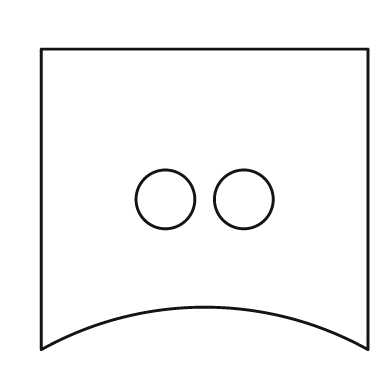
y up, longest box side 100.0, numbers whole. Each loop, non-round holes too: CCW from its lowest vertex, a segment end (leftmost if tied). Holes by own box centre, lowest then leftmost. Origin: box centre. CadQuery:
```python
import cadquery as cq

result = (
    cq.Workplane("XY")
    .moveTo(-50.0, -46.0)
    .threePointArc((0.0, -33.0), (50.0, -46.0))
    .lineTo(50.0, 46.0)
    .lineTo(-50.0, 46.0)
    .close()
    .moveTo(-12.0, 0.0)
    .circle(9.0)
    .moveTo(12.0, 0.0)
    .circle(9.0)
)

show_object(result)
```